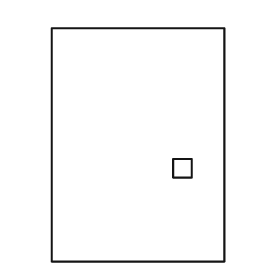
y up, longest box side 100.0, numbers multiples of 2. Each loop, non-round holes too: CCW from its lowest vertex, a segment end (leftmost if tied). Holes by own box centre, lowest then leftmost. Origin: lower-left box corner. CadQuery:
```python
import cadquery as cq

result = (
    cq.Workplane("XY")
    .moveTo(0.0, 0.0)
    .lineTo(74.0, 0.0)
    .lineTo(74.0, 100.0)
    .lineTo(0.0, 100.0)
    .close()
    .moveTo(52.0, 36.0)
    .lineTo(60.0, 36.0)
    .lineTo(60.0, 44.0)
    .lineTo(52.0, 44.0)
    .close()
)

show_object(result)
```